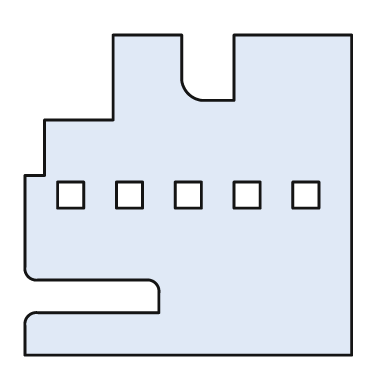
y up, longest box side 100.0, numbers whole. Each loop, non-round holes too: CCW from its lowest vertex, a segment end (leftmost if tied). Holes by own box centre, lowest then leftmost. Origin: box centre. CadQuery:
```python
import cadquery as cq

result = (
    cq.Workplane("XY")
    .moveTo(-50.0, -49.0)
    .lineTo(50.0, -49.0)
    .lineTo(50.0, 49.0)
    .lineTo(14.0, 49.0)
    .lineTo(14.0, 29.0)
    .lineTo(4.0, 29.0)
    .threePointArc((0.0, 31.0), (-2.0, 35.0))
    .lineTo(-2.0, 49.0)
    .lineTo(-23.0, 49.0)
    .lineTo(-23.0, 23.0)
    .lineTo(-44.0, 23.0)
    .lineTo(-44.0, 6.0)
    .lineTo(-50.0, 6.0)
    .lineTo(-50.0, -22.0)
    .threePointArc((-49.0, -25.0), (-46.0, -26.0))
    .lineTo(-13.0, -26.0)
    .threePointArc((-10.0, -27.0), (-9.0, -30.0))
    .lineTo(-9.0, -36.0)
    .lineTo(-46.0, -36.0)
    .threePointArc((-49.0, -37.0), (-50.0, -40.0))
    .close()
    .moveTo(-40.0, -4.0)
    .lineTo(-32.0, -4.0)
    .lineTo(-32.0, 4.0)
    .lineTo(-40.0, 4.0)
    .close()
    .moveTo(-22.0, -4.0)
    .lineTo(-14.0, -4.0)
    .lineTo(-14.0, 4.0)
    .lineTo(-22.0, 4.0)
    .close()
    .moveTo(-4.0, -4.0)
    .lineTo(4.0, -4.0)
    .lineTo(4.0, 4.0)
    .lineTo(-4.0, 4.0)
    .close()
    .moveTo(14.0, -4.0)
    .lineTo(22.0, -4.0)
    .lineTo(22.0, 4.0)
    .lineTo(14.0, 4.0)
    .close()
    .moveTo(32.0, -4.0)
    .lineTo(40.0, -4.0)
    .lineTo(40.0, 4.0)
    .lineTo(32.0, 4.0)
    .close()
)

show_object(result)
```